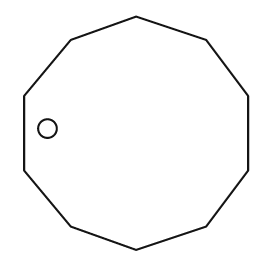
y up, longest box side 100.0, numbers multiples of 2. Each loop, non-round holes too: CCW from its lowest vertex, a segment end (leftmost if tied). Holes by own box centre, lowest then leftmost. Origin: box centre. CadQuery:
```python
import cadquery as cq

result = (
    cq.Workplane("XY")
    .moveTo(0.0, -50.0)
    .lineTo(30.0, -40.0)
    .lineTo(48.0, -16.0)
    .lineTo(48.0, 16.0)
    .lineTo(30.0, 40.0)
    .lineTo(0.0, 50.0)
    .lineTo(-28.0, 40.0)
    .lineTo(-48.0, 16.0)
    .lineTo(-48.0, -16.0)
    .lineTo(-28.0, -40.0)
    .close()
    .moveTo(-38.0, 2.0)
    .circle(4.0)
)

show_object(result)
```